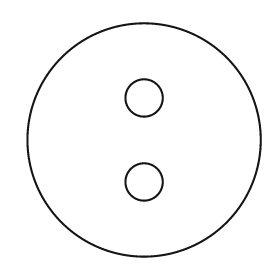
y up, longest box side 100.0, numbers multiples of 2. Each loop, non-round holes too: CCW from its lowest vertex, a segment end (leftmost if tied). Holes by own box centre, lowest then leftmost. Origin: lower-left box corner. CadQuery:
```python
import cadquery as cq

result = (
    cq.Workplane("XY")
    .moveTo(50.0, 50.0)
    .circle(50.0)
    .moveTo(50.0, 32.0)
    .circle(8.0)
    .moveTo(50.0, 68.0)
    .circle(8.0)
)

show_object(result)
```